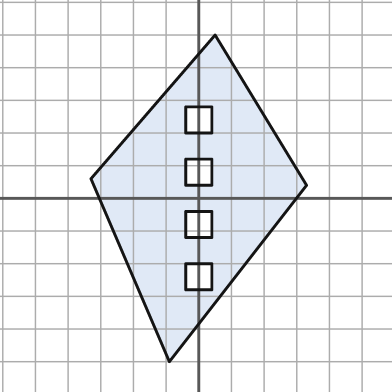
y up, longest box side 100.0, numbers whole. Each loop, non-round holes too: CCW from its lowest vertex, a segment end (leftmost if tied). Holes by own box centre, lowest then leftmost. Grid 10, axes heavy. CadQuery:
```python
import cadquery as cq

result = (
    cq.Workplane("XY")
    .moveTo(-9.0, -50.0)
    .lineTo(33.0, 4.0)
    .lineTo(5.0, 50.0)
    .lineTo(-33.0, 6.0)
    .close()
    .moveTo(-4.0, -28.0)
    .lineTo(4.0, -28.0)
    .lineTo(4.0, -20.0)
    .lineTo(-4.0, -20.0)
    .close()
    .moveTo(-4.0, -12.0)
    .lineTo(4.0, -12.0)
    .lineTo(4.0, -4.0)
    .lineTo(-4.0, -4.0)
    .close()
    .moveTo(-4.0, 4.0)
    .lineTo(4.0, 4.0)
    .lineTo(4.0, 12.0)
    .lineTo(-4.0, 12.0)
    .close()
    .moveTo(-4.0, 20.0)
    .lineTo(4.0, 20.0)
    .lineTo(4.0, 28.0)
    .lineTo(-4.0, 28.0)
    .close()
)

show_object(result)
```